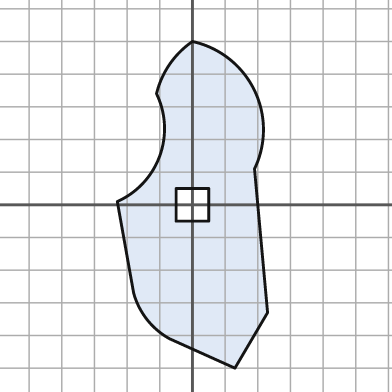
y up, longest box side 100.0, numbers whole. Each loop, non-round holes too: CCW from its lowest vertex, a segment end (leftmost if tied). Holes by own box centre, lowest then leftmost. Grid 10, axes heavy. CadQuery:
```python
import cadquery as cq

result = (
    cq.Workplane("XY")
    .moveTo(13.0, -50.0)
    .lineTo(23.0, -33.0)
    .lineTo(19.0, 11.0)
    .threePointArc((19.0, 35.0), (0.0, 50.0))
    .threePointArc((-7.0, 43.0), (-11.0, 34.0))
    .threePointArc((-10.0, 15.0), (-23.0, 1.0))
    .lineTo(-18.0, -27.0)
    .threePointArc((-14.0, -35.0), (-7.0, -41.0))
    .close()
    .moveTo(-5.0, -5.0)
    .lineTo(5.0, -5.0)
    .lineTo(5.0, 5.0)
    .lineTo(-5.0, 5.0)
    .close()
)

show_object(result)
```